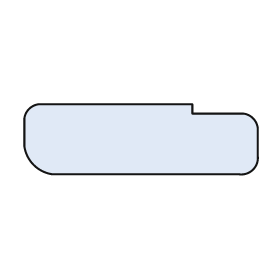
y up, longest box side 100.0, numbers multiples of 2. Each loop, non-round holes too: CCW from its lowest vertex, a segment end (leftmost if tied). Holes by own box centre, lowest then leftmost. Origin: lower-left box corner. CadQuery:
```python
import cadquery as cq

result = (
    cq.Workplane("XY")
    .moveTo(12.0, 0.0)
    .lineTo(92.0, 0.0)
    .threePointArc((98.0, 2.0), (100.0, 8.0))
    .lineTo(100.0, 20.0)
    .threePointArc((98.0, 24.0), (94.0, 26.0))
    .lineTo(72.0, 26.0)
    .lineTo(72.0, 30.0)
    .lineTo(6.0, 30.0)
    .threePointArc((2.0, 28.0), (0.0, 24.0))
    .lineTo(0.0, 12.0)
    .threePointArc((4.0, 4.0), (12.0, 0.0))
    .close()
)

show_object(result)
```